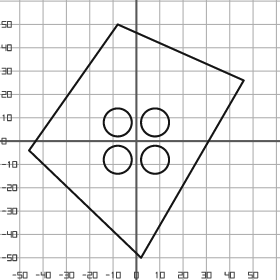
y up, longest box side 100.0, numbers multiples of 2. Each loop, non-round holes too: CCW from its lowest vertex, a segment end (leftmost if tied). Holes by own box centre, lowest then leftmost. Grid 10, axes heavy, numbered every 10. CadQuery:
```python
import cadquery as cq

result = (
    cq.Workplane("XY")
    .moveTo(2.0, -50.0)
    .lineTo(46.0, 26.0)
    .lineTo(-8.0, 50.0)
    .lineTo(-46.0, -4.0)
    .close()
    .moveTo(-8.0, -8.0)
    .circle(6.0)
    .moveTo(8.0, -8.0)
    .circle(6.0)
    .moveTo(-8.0, 8.0)
    .circle(6.0)
    .moveTo(8.0, 8.0)
    .circle(6.0)
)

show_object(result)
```